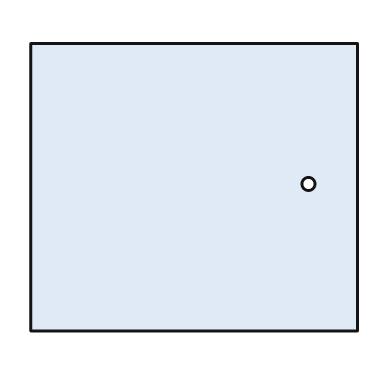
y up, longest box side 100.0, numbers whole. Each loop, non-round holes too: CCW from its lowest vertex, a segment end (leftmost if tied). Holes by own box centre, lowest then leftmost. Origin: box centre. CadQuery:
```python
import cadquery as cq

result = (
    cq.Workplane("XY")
    .moveTo(-50.0, -44.0)
    .lineTo(50.0, -44.0)
    .lineTo(50.0, 44.0)
    .lineTo(-50.0, 44.0)
    .close()
    .moveTo(35.0, 1.0)
    .circle(2.0)
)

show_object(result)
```